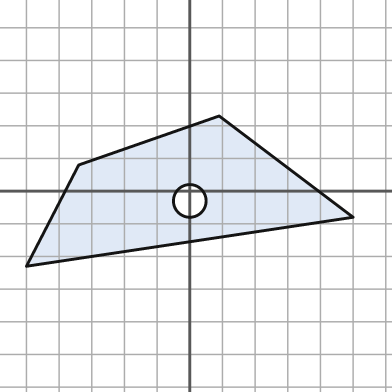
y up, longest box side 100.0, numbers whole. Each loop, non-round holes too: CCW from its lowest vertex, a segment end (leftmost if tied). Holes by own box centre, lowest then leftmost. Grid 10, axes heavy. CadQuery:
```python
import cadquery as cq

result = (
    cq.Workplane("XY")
    .moveTo(-50.0, -23.0)
    .lineTo(50.0, -8.0)
    .lineTo(9.0, 23.0)
    .lineTo(-34.0, 8.0)
    .close()
    .moveTo(0.0, -3.0)
    .circle(5.0)
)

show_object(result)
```